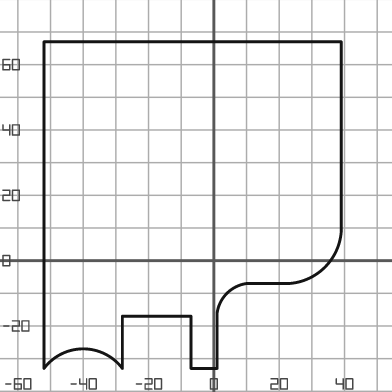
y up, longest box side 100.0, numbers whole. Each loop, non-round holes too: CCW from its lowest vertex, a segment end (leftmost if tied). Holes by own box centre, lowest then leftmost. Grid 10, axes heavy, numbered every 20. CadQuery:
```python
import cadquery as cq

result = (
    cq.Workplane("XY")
    .moveTo(-52.0, -33.0)
    .threePointArc((-40.0, -27.0), (-28.0, -33.0))
    .lineTo(-28.0, -17.0)
    .lineTo(-7.0, -17.0)
    .lineTo(-7.0, -33.0)
    .lineTo(1.0, -33.0)
    .lineTo(1.0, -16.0)
    .threePointArc((4.0, -10.0), (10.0, -7.0))
    .lineTo(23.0, -7.0)
    .threePointArc((34.0, -2.0), (39.0, 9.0))
    .lineTo(39.0, 67.0)
    .lineTo(-52.0, 67.0)
    .close()
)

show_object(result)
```